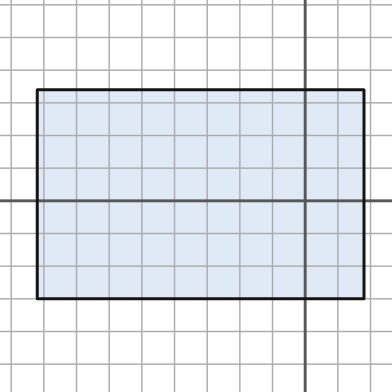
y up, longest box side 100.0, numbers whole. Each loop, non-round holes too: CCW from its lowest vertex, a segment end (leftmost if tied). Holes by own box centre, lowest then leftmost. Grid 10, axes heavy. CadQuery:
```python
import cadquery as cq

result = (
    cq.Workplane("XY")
    .moveTo(-82.0, -30.0)
    .lineTo(18.0, -30.0)
    .lineTo(18.0, 34.0)
    .lineTo(-82.0, 34.0)
    .close()
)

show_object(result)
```